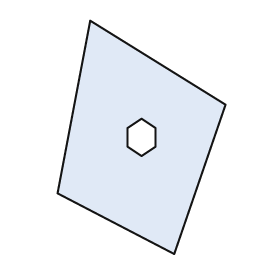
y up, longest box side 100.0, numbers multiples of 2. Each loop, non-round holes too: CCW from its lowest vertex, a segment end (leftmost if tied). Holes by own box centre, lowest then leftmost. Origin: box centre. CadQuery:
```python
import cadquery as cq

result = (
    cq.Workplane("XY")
    .moveTo(14.0, -50.0)
    .lineTo(36.0, 14.0)
    .lineTo(-22.0, 50.0)
    .lineTo(-36.0, -24.0)
    .close()
    .moveTo(0.0, -8.0)
    .lineTo(6.0, -4.0)
    .lineTo(6.0, 4.0)
    .lineTo(0.0, 8.0)
    .lineTo(-6.0, 4.0)
    .lineTo(-6.0, -4.0)
    .close()
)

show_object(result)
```